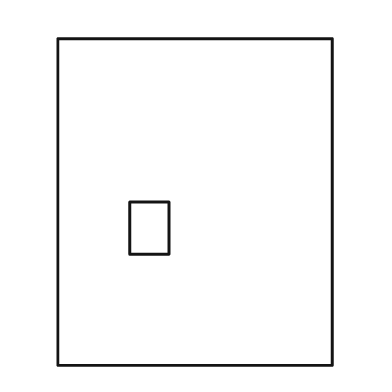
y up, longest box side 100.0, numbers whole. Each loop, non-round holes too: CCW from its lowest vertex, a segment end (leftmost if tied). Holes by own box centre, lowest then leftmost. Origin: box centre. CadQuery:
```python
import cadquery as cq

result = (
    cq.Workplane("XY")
    .moveTo(-42.0, -50.0)
    .lineTo(42.0, -50.0)
    .lineTo(42.0, 50.0)
    .lineTo(-42.0, 50.0)
    .close()
    .moveTo(-20.0, -16.0)
    .lineTo(-8.0, -16.0)
    .lineTo(-8.0, 0.0)
    .lineTo(-20.0, 0.0)
    .close()
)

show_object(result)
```